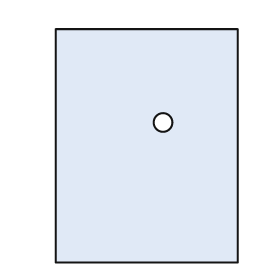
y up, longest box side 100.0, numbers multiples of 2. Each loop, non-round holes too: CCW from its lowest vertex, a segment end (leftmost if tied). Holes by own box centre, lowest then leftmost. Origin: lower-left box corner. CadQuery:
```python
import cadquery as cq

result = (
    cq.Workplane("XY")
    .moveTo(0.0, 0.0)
    .lineTo(78.0, 0.0)
    .lineTo(78.0, 100.0)
    .lineTo(0.0, 100.0)
    .close()
    .moveTo(46.0, 60.0)
    .circle(4.0)
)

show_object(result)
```